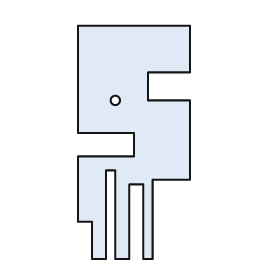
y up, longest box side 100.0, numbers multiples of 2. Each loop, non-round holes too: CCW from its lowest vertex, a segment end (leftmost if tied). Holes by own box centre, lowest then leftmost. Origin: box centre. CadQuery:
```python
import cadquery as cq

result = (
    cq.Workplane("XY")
    .moveTo(-18.0, -50.0)
    .lineTo(-12.0, -50.0)
    .lineTo(-12.0, -12.0)
    .lineTo(-8.0, -12.0)
    .lineTo(-8.0, -50.0)
    .lineTo(-2.0, -50.0)
    .lineTo(-2.0, -18.0)
    .lineTo(4.0, -18.0)
    .lineTo(4.0, -50.0)
    .lineTo(8.0, -50.0)
    .lineTo(8.0, -16.0)
    .lineTo(24.0, -16.0)
    .lineTo(24.0, 18.0)
    .lineTo(6.0, 18.0)
    .lineTo(6.0, 30.0)
    .lineTo(24.0, 30.0)
    .lineTo(24.0, 50.0)
    .lineTo(-24.0, 50.0)
    .lineTo(-24.0, 4.0)
    .lineTo(0.0, 4.0)
    .lineTo(0.0, -6.0)
    .lineTo(-24.0, -6.0)
    .lineTo(-24.0, -34.0)
    .lineTo(-18.0, -34.0)
    .close()
    .moveTo(-8.0, 18.0)
    .circle(2.0)
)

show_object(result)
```